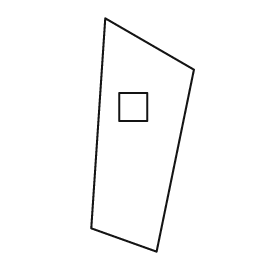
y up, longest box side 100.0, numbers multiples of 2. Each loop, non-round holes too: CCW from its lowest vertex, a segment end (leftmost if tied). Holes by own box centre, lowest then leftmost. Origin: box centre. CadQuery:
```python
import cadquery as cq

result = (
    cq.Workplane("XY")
    .moveTo(6.0, -50.0)
    .lineTo(22.0, 28.0)
    .lineTo(-16.0, 50.0)
    .lineTo(-22.0, -40.0)
    .close()
    .moveTo(-10.0, 6.0)
    .lineTo(2.0, 6.0)
    .lineTo(2.0, 18.0)
    .lineTo(-10.0, 18.0)
    .close()
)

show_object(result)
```